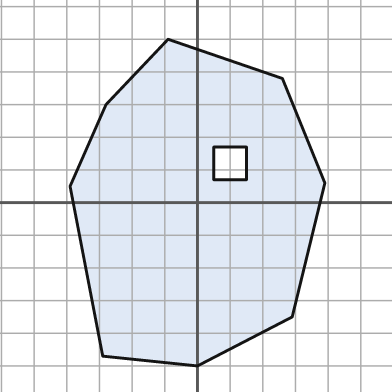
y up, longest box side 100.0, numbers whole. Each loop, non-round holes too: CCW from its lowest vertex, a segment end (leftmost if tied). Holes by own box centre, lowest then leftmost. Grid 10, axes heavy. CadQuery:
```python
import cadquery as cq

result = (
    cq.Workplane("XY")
    .moveTo(0.0, -50.0)
    .lineTo(29.0, -35.0)
    .lineTo(39.0, 6.0)
    .lineTo(26.0, 38.0)
    .lineTo(-9.0, 50.0)
    .lineTo(-28.0, 30.0)
    .lineTo(-39.0, 5.0)
    .lineTo(-29.0, -47.0)
    .close()
    .moveTo(5.0, 7.0)
    .lineTo(15.0, 7.0)
    .lineTo(15.0, 17.0)
    .lineTo(5.0, 17.0)
    .close()
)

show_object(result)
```